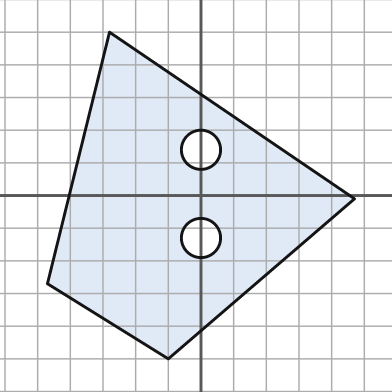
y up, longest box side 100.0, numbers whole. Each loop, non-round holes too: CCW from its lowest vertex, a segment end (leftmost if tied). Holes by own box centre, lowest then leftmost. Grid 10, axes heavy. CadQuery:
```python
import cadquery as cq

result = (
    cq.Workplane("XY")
    .moveTo(-10.0, -50.0)
    .lineTo(47.0, -1.0)
    .lineTo(-28.0, 50.0)
    .lineTo(-47.0, -27.0)
    .close()
    .moveTo(0.0, -13.0)
    .circle(6.0)
    .moveTo(0.0, 14.0)
    .circle(6.0)
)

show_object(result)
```